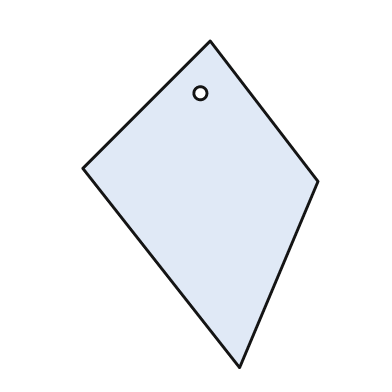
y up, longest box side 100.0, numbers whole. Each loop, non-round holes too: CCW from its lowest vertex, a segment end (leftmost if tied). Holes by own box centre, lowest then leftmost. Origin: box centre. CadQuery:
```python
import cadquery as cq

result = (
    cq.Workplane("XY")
    .moveTo(12.0, -50.0)
    .lineTo(36.0, 7.0)
    .lineTo(3.0, 50.0)
    .lineTo(-36.0, 11.0)
    .close()
    .moveTo(0.0, 34.0)
    .circle(2.0)
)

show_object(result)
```